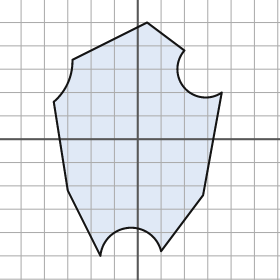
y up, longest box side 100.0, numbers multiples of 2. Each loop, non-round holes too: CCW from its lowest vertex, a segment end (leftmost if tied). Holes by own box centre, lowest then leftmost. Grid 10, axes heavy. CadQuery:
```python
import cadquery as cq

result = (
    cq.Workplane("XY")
    .moveTo(-16.0, -50.0)
    .threePointArc((-4.0, -38.0), (10.0, -48.0))
    .lineTo(28.0, -24.0)
    .lineTo(36.0, 20.0)
    .threePointArc((20.0, 22.0), (20.0, 38.0))
    .lineTo(4.0, 50.0)
    .lineTo(-28.0, 34.0)
    .threePointArc((-30.0, 24.0), (-36.0, 16.0))
    .lineTo(-30.0, -22.0)
    .close()
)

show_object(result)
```